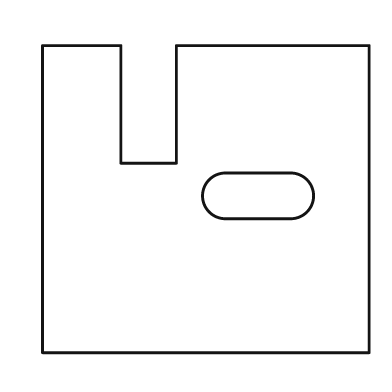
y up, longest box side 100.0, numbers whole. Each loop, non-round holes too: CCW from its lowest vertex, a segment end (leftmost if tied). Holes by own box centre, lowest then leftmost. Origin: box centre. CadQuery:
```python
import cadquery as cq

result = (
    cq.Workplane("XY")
    .moveTo(-50.0, -47.0)
    .lineTo(50.0, -47.0)
    .lineTo(50.0, 47.0)
    .lineTo(-9.0, 47.0)
    .lineTo(-9.0, 11.0)
    .lineTo(-26.0, 11.0)
    .lineTo(-26.0, 47.0)
    .lineTo(-50.0, 47.0)
    .close()
    .moveTo(6.0, -6.0)
    .lineTo(26.0, -6.0)
    .threePointArc((33.0, 1.0), (26.0, 8.0))
    .lineTo(6.0, 8.0)
    .threePointArc((-1.0, 1.0), (6.0, -6.0))
    .close()
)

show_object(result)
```